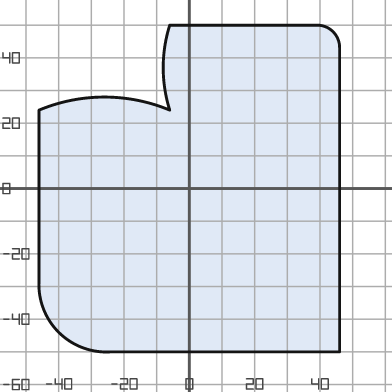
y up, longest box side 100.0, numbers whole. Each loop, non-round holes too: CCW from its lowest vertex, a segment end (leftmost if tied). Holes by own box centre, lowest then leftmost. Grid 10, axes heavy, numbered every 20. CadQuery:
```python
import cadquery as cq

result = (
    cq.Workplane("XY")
    .moveTo(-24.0, -50.0)
    .lineTo(46.0, -50.0)
    .lineTo(46.0, 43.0)
    .threePointArc((44.0, 48.0), (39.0, 50.0))
    .lineTo(-6.0, 50.0)
    .threePointArc((-8.0, 37.0), (-6.0, 24.0))
    .threePointArc((-26.0, 28.0), (-46.0, 24.0))
    .lineTo(-46.0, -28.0)
    .threePointArc((-40.0, -44.0), (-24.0, -50.0))
    .close()
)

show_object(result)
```